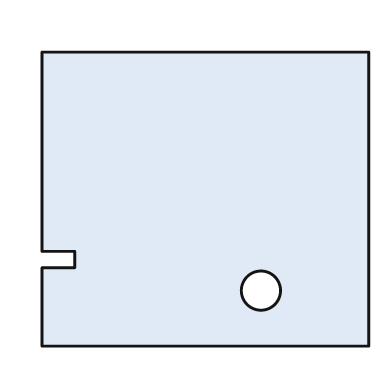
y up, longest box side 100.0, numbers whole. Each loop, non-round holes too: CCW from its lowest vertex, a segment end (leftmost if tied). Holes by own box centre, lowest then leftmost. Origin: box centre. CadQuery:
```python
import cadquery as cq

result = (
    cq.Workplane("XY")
    .moveTo(-50.0, -45.0)
    .lineTo(50.0, -45.0)
    .lineTo(50.0, 45.0)
    .lineTo(-50.0, 45.0)
    .lineTo(-50.0, -16.0)
    .lineTo(-40.0, -16.0)
    .lineTo(-40.0, -21.0)
    .lineTo(-50.0, -21.0)
    .close()
    .moveTo(17.0, -28.0)
    .circle(6.0)
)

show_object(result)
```